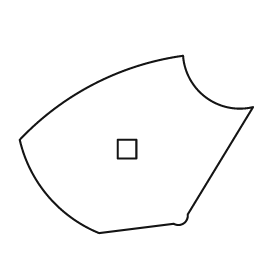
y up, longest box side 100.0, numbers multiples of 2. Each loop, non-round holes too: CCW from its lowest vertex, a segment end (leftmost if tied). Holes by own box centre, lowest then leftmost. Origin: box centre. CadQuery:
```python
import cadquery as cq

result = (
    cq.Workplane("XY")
    .moveTo(-16.0, -38.0)
    .lineTo(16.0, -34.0)
    .threePointArc((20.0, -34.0), (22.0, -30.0))
    .lineTo(50.0, 16.0)
    .threePointArc((30.0, 20.0), (20.0, 38.0))
    .threePointArc((-18.0, 26.0), (-50.0, 2.0))
    .threePointArc((-38.0, -22.0), (-16.0, -38.0))
    .close()
    .moveTo(-8.0, -6.0)
    .lineTo(0.0, -6.0)
    .lineTo(0.0, 2.0)
    .lineTo(-8.0, 2.0)
    .close()
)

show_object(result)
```